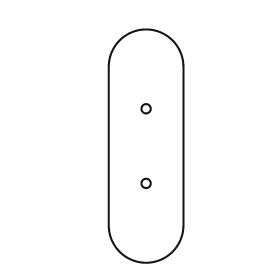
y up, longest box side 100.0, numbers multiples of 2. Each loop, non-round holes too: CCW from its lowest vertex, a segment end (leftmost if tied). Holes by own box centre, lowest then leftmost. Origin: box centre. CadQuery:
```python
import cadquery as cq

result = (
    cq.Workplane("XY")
    .moveTo(-16.0, -34.0)
    .threePointArc((0.0, -50.0), (16.0, -34.0))
    .lineTo(16.0, 34.0)
    .threePointArc((0.0, 50.0), (-16.0, 34.0))
    .close()
    .moveTo(0.0, -16.0)
    .circle(2.0)
    .moveTo(0.0, 16.0)
    .circle(2.0)
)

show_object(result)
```